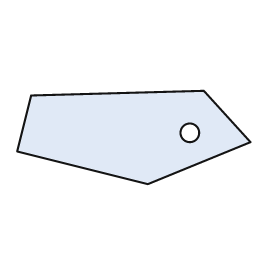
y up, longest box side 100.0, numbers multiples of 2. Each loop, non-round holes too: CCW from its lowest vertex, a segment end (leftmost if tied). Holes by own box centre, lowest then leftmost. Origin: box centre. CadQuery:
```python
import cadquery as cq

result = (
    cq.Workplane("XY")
    .moveTo(6.0, -20.0)
    .lineTo(50.0, -2.0)
    .lineTo(30.0, 20.0)
    .lineTo(-44.0, 18.0)
    .lineTo(-50.0, -6.0)
    .close()
    .moveTo(24.0, 2.0)
    .circle(4.0)
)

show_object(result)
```